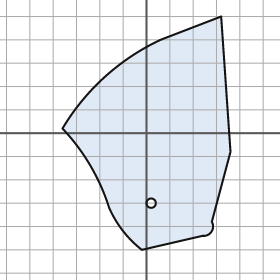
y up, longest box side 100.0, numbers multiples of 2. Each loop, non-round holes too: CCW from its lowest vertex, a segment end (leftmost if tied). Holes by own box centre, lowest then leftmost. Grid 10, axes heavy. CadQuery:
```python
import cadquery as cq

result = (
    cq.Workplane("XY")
    .moveTo(-2.0, -50.0)
    .lineTo(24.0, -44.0)
    .threePointArc((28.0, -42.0), (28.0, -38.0))
    .lineTo(36.0, -8.0)
    .lineTo(32.0, 50.0)
    .lineTo(6.0, 40.0)
    .threePointArc((-18.0, 24.0), (-36.0, 2.0))
    .threePointArc((-24.0, -14.0), (-16.0, -32.0))
    .threePointArc((-10.0, -42.0), (-2.0, -50.0))
    .close()
    .moveTo(2.0, -30.0)
    .circle(2.0)
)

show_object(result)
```